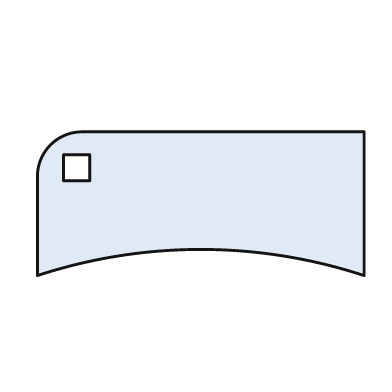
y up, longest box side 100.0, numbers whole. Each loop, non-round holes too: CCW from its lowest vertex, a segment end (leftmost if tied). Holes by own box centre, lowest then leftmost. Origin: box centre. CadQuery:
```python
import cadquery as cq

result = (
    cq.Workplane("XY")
    .moveTo(-50.0, -22.0)
    .threePointArc((0.0, -14.0), (50.0, -22.0))
    .lineTo(50.0, 22.0)
    .lineTo(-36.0, 22.0)
    .threePointArc((-46.0, 18.0), (-50.0, 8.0))
    .close()
    .moveTo(-42.0, 7.0)
    .lineTo(-34.0, 7.0)
    .lineTo(-34.0, 15.0)
    .lineTo(-42.0, 15.0)
    .close()
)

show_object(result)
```